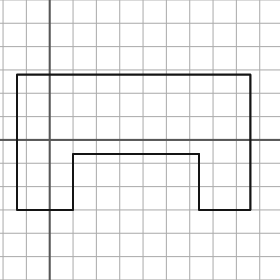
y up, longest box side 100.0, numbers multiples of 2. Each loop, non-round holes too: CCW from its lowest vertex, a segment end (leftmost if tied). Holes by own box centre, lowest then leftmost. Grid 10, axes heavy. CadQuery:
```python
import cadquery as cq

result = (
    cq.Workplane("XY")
    .moveTo(-14.0, -30.0)
    .lineTo(10.0, -30.0)
    .lineTo(10.0, -6.0)
    .lineTo(64.0, -6.0)
    .lineTo(64.0, -30.0)
    .lineTo(86.0, -30.0)
    .lineTo(86.0, 28.0)
    .lineTo(-14.0, 28.0)
    .close()
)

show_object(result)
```